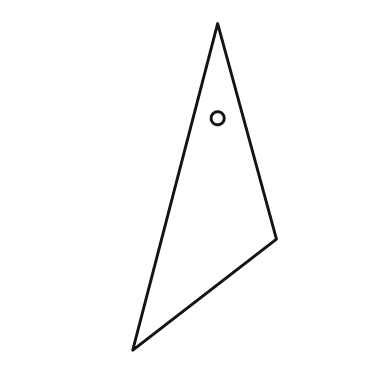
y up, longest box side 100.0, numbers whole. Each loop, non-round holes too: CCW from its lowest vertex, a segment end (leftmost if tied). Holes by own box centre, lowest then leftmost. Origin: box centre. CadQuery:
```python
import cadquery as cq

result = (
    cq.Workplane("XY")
    .moveTo(-22.0, -50.0)
    .lineTo(22.0, -16.0)
    .lineTo(4.0, 50.0)
    .close()
    .moveTo(4.0, 21.0)
    .circle(2.0)
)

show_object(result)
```